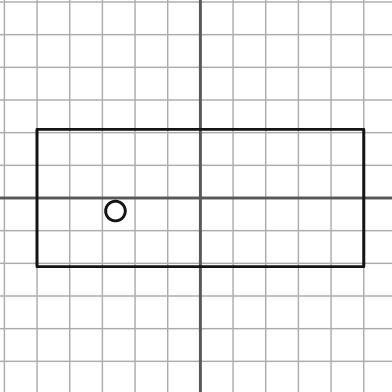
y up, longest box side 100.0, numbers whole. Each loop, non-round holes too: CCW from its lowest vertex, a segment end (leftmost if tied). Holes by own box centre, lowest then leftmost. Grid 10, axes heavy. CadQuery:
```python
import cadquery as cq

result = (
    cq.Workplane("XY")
    .moveTo(-50.0, -21.0)
    .lineTo(50.0, -21.0)
    .lineTo(50.0, 21.0)
    .lineTo(-50.0, 21.0)
    .close()
    .moveTo(-26.0, -4.0)
    .circle(3.0)
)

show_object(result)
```